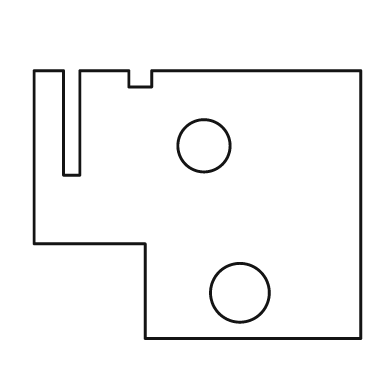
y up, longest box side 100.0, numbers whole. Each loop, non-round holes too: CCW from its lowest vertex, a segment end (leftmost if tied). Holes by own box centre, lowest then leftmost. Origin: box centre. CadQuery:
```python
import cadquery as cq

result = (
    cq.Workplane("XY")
    .moveTo(-16.0, -41.0)
    .lineTo(50.0, -41.0)
    .lineTo(50.0, 41.0)
    .lineTo(-14.0, 41.0)
    .lineTo(-14.0, 36.0)
    .lineTo(-21.0, 36.0)
    .lineTo(-21.0, 41.0)
    .lineTo(-36.0, 41.0)
    .lineTo(-36.0, 9.0)
    .lineTo(-41.0, 9.0)
    .lineTo(-41.0, 41.0)
    .lineTo(-50.0, 41.0)
    .lineTo(-50.0, -12.0)
    .lineTo(-16.0, -12.0)
    .close()
    .moveTo(13.0, -27.0)
    .circle(9.0)
    .moveTo(2.0, 18.0)
    .circle(8.0)
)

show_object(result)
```